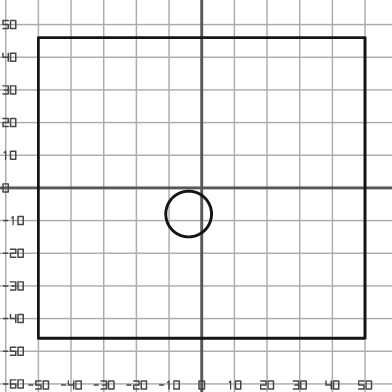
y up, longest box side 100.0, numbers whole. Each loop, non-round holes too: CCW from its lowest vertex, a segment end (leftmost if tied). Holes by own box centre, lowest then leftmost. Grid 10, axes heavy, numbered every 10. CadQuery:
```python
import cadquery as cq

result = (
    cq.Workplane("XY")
    .moveTo(-50.0, -46.0)
    .lineTo(50.0, -46.0)
    .lineTo(50.0, 46.0)
    .lineTo(-50.0, 46.0)
    .close()
    .moveTo(-4.0, -8.0)
    .circle(7.0)
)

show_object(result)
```